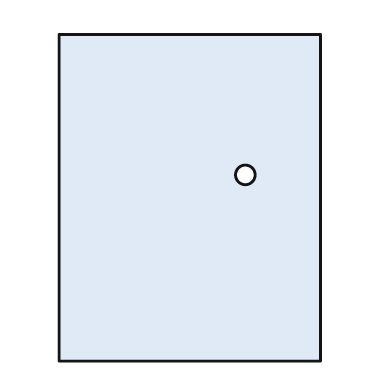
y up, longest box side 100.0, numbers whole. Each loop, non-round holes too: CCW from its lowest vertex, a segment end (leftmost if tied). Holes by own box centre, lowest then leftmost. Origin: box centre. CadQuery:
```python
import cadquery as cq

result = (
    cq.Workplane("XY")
    .moveTo(-40.0, -50.0)
    .lineTo(40.0, -50.0)
    .lineTo(40.0, 50.0)
    .lineTo(-40.0, 50.0)
    .close()
    .moveTo(17.0, 7.0)
    .circle(3.0)
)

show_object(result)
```